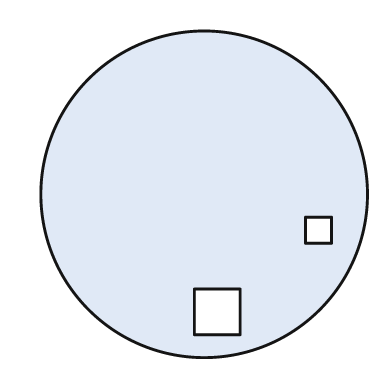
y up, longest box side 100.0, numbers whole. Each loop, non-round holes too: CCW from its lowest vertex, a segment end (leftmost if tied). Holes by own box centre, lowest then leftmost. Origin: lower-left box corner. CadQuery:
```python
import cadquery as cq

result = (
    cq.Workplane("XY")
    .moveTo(50.0, 50.0)
    .circle(50.0)
    .moveTo(47.0, 7.0)
    .lineTo(61.0, 7.0)
    .lineTo(61.0, 21.0)
    .lineTo(47.0, 21.0)
    .close()
    .moveTo(81.0, 35.0)
    .lineTo(89.0, 35.0)
    .lineTo(89.0, 43.0)
    .lineTo(81.0, 43.0)
    .close()
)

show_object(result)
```